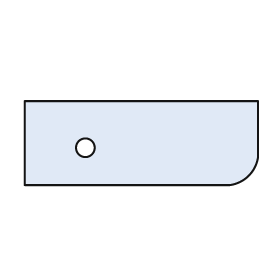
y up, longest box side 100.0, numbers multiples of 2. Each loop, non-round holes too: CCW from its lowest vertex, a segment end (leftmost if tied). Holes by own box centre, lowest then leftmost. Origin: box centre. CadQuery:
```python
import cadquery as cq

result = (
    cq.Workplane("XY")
    .moveTo(-50.0, -18.0)
    .lineTo(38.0, -18.0)
    .threePointArc((46.0, -14.0), (50.0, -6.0))
    .lineTo(50.0, 18.0)
    .lineTo(-50.0, 18.0)
    .close()
    .moveTo(-24.0, -2.0)
    .circle(4.0)
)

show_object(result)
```